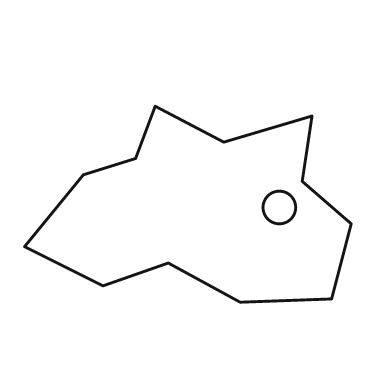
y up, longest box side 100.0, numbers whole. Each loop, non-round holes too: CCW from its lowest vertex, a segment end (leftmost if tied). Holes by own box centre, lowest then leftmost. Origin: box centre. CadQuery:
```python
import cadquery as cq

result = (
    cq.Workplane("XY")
    .moveTo(16.0, -30.0)
    .lineTo(44.0, -29.0)
    .lineTo(50.0, -6.0)
    .lineTo(35.0, 7.0)
    .lineTo(38.0, 27.0)
    .lineTo(11.0, 19.0)
    .lineTo(-10.0, 30.0)
    .lineTo(-16.0, 14.0)
    .lineTo(-32.0, 9.0)
    .lineTo(-50.0, -13.0)
    .lineTo(-26.0, -25.0)
    .lineTo(-6.0, -18.0)
    .close()
    .moveTo(28.0, -1.0)
    .circle(5.0)
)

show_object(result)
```